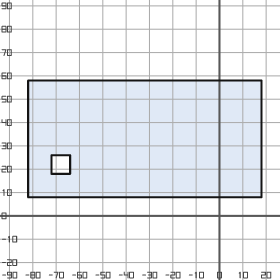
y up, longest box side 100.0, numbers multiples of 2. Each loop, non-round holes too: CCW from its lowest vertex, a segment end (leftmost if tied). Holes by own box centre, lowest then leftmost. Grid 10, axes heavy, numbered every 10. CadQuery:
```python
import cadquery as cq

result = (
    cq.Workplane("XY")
    .moveTo(-82.0, 8.0)
    .lineTo(18.0, 8.0)
    .lineTo(18.0, 58.0)
    .lineTo(-82.0, 58.0)
    .close()
    .moveTo(-72.0, 18.0)
    .lineTo(-64.0, 18.0)
    .lineTo(-64.0, 26.0)
    .lineTo(-72.0, 26.0)
    .close()
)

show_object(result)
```